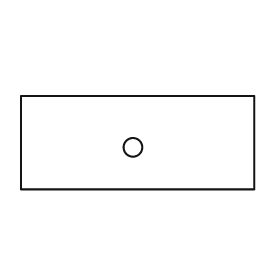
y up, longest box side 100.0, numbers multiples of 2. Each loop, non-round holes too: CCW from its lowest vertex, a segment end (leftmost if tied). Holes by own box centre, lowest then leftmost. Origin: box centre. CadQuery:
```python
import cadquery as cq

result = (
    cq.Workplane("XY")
    .moveTo(-50.0, -20.0)
    .lineTo(50.0, -20.0)
    .lineTo(50.0, 20.0)
    .lineTo(-50.0, 20.0)
    .close()
    .moveTo(-2.0, -2.0)
    .circle(4.0)
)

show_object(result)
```